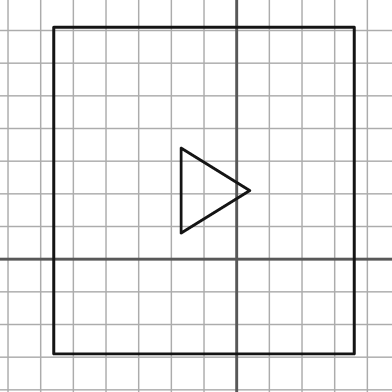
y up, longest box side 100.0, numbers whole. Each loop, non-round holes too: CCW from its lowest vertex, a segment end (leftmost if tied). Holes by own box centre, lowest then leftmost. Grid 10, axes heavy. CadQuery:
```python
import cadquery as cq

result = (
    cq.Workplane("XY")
    .moveTo(-56.0, -29.0)
    .lineTo(36.0, -29.0)
    .lineTo(36.0, 71.0)
    .lineTo(-56.0, 71.0)
    .close()
    .moveTo(-17.0, 8.0)
    .lineTo(4.0, 21.0)
    .lineTo(-17.0, 34.0)
    .close()
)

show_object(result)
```